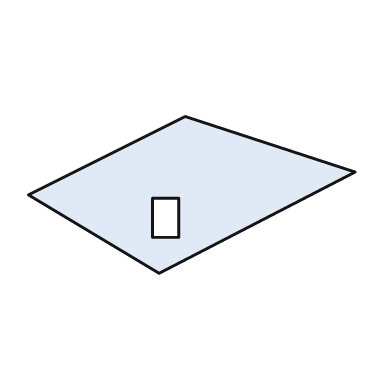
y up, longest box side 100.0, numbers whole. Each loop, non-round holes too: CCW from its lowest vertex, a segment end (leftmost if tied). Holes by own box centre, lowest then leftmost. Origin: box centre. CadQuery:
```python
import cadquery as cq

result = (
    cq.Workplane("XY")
    .moveTo(-10.0, -24.0)
    .lineTo(50.0, 7.0)
    .lineTo(-2.0, 24.0)
    .lineTo(-50.0, 0.0)
    .close()
    .moveTo(-12.0, -13.0)
    .lineTo(-4.0, -13.0)
    .lineTo(-4.0, -1.0)
    .lineTo(-12.0, -1.0)
    .close()
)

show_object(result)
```